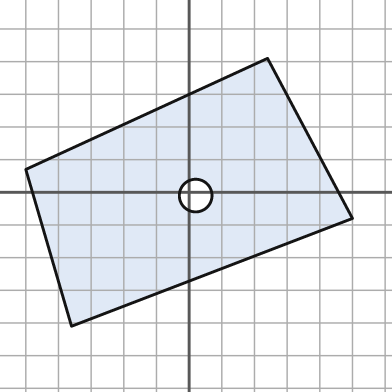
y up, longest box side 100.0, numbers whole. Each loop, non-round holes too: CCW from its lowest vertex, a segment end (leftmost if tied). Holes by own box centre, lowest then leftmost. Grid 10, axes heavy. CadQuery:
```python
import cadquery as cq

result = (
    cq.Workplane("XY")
    .moveTo(-36.0, -41.0)
    .lineTo(50.0, -8.0)
    .lineTo(24.0, 41.0)
    .lineTo(-50.0, 7.0)
    .close()
    .moveTo(2.0, -1.0)
    .circle(5.0)
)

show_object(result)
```